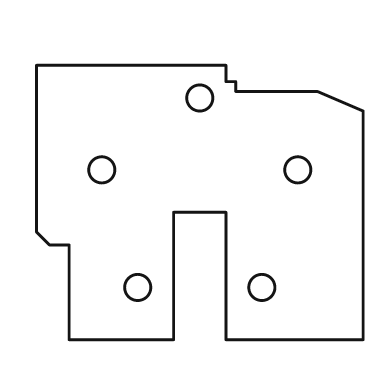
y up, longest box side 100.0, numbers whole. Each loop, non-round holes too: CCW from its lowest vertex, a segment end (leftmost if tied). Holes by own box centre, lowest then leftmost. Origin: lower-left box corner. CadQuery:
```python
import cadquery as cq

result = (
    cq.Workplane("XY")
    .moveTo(10.0, 0.0)
    .lineTo(42.0, 0.0)
    .lineTo(42.0, 39.0)
    .lineTo(58.0, 39.0)
    .lineTo(58.0, 0.0)
    .lineTo(100.0, 0.0)
    .lineTo(100.0, 70.0)
    .lineTo(86.0, 76.0)
    .lineTo(61.0, 76.0)
    .lineTo(61.0, 79.0)
    .lineTo(58.0, 79.0)
    .lineTo(58.0, 84.0)
    .lineTo(0.0, 84.0)
    .lineTo(0.0, 33.0)
    .lineTo(4.0, 29.0)
    .lineTo(10.0, 29.0)
    .close()
    .moveTo(31.0, 16.0)
    .circle(4.0)
    .moveTo(69.0, 16.0)
    .circle(4.0)
    .moveTo(20.0, 52.0)
    .circle(4.0)
    .moveTo(80.0, 52.0)
    .circle(4.0)
    .moveTo(50.0, 74.0)
    .circle(4.0)
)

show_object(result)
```